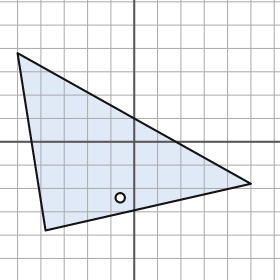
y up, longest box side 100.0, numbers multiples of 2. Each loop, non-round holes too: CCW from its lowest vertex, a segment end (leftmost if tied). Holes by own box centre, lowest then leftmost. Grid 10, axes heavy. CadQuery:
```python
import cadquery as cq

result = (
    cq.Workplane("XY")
    .moveTo(-38.0, -38.0)
    .lineTo(50.0, -18.0)
    .lineTo(-50.0, 38.0)
    .close()
    .moveTo(-6.0, -24.0)
    .circle(2.0)
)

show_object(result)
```